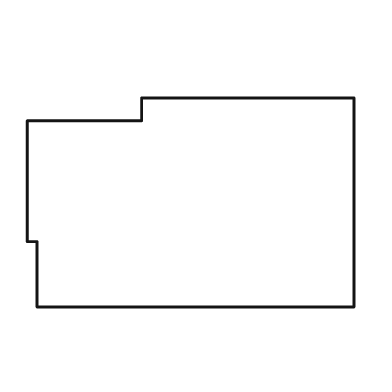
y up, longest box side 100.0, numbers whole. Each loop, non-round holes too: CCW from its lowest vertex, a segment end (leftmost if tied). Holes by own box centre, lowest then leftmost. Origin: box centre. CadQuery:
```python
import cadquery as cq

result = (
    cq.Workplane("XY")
    .moveTo(-47.0, -32.0)
    .lineTo(50.0, -32.0)
    .lineTo(50.0, 32.0)
    .lineTo(-15.0, 32.0)
    .lineTo(-15.0, 25.0)
    .lineTo(-50.0, 25.0)
    .lineTo(-50.0, -12.0)
    .lineTo(-47.0, -12.0)
    .close()
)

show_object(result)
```